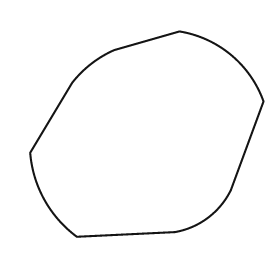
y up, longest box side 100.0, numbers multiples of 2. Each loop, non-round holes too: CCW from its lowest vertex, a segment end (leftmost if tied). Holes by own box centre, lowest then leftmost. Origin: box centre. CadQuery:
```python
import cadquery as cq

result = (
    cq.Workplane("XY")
    .moveTo(-30.0, -44.0)
    .lineTo(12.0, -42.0)
    .threePointArc((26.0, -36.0), (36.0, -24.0))
    .lineTo(50.0, 14.0)
    .threePointArc((36.0, 34.0), (14.0, 44.0))
    .lineTo(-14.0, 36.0)
    .threePointArc((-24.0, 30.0), (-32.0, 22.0))
    .lineTo(-50.0, -8.0)
    .threePointArc((-44.0, -28.0), (-30.0, -44.0))
    .close()
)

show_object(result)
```